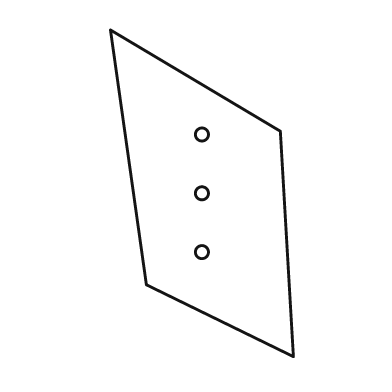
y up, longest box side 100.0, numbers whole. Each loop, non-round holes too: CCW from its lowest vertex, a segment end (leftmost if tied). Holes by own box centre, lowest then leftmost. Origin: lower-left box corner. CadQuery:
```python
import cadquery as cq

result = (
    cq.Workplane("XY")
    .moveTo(56.0, 0.0)
    .lineTo(52.0, 69.0)
    .lineTo(0.0, 100.0)
    .lineTo(11.0, 22.0)
    .close()
    .moveTo(28.0, 32.0)
    .circle(2.0)
    .moveTo(28.0, 50.0)
    .circle(2.0)
    .moveTo(28.0, 68.0)
    .circle(2.0)
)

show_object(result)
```